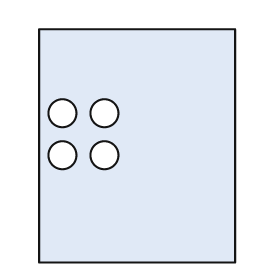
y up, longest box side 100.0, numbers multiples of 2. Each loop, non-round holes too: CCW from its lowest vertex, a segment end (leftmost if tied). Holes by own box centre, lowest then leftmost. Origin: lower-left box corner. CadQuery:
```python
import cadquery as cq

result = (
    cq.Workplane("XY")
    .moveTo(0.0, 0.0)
    .lineTo(84.0, 0.0)
    .lineTo(84.0, 100.0)
    .lineTo(0.0, 100.0)
    .close()
    .moveTo(10.0, 46.0)
    .circle(6.0)
    .moveTo(28.0, 46.0)
    .circle(6.0)
    .moveTo(10.0, 64.0)
    .circle(6.0)
    .moveTo(28.0, 64.0)
    .circle(6.0)
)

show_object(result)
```